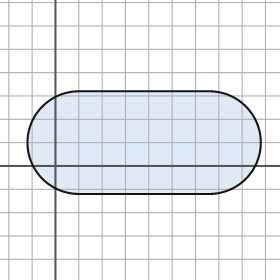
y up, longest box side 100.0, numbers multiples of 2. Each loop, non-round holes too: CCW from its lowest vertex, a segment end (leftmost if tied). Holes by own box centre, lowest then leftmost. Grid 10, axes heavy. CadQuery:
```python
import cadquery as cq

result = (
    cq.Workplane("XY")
    .moveTo(10.0, -12.0)
    .lineTo(66.0, -12.0)
    .threePointArc((88.0, 10.0), (66.0, 32.0))
    .lineTo(10.0, 32.0)
    .threePointArc((-12.0, 10.0), (10.0, -12.0))
    .close()
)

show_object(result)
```